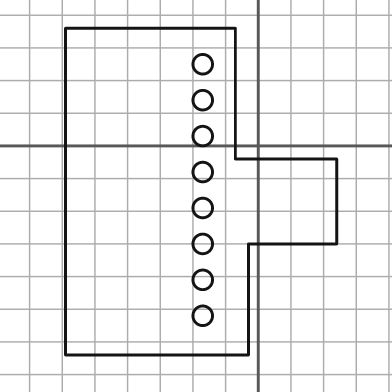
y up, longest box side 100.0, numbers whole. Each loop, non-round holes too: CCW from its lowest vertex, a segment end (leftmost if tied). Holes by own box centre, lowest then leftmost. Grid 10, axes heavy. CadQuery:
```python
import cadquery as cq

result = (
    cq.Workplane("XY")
    .moveTo(-59.0, -64.0)
    .lineTo(-3.0, -64.0)
    .lineTo(-3.0, -30.0)
    .lineTo(24.0, -30.0)
    .lineTo(24.0, -4.0)
    .lineTo(-7.0, -4.0)
    .lineTo(-7.0, 36.0)
    .lineTo(-59.0, 36.0)
    .close()
    .moveTo(-17.0, -52.0)
    .circle(3.0)
    .moveTo(-17.0, -41.0)
    .circle(3.0)
    .moveTo(-17.0, -30.0)
    .circle(3.0)
    .moveTo(-17.0, -19.0)
    .circle(3.0)
    .moveTo(-17.0, -8.0)
    .circle(3.0)
    .moveTo(-17.0, 3.0)
    .circle(3.0)
    .moveTo(-17.0, 14.0)
    .circle(3.0)
    .moveTo(-17.0, 25.0)
    .circle(3.0)
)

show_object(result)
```